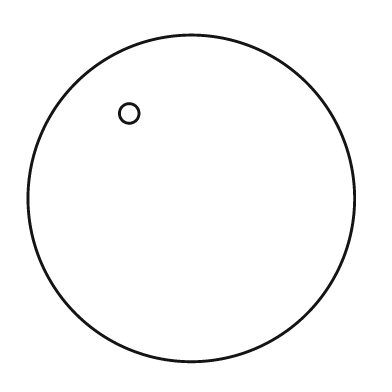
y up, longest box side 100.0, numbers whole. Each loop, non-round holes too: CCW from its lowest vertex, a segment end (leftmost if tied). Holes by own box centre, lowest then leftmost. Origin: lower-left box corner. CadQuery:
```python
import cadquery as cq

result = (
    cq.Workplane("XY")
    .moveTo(50.0, 50.0)
    .circle(50.0)
    .moveTo(31.0, 76.0)
    .circle(3.0)
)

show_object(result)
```